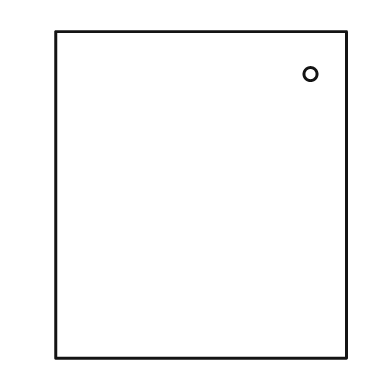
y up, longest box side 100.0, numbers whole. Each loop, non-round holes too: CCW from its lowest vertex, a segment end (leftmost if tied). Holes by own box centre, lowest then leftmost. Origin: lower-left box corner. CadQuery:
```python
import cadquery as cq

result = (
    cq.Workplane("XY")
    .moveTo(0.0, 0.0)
    .lineTo(89.0, 0.0)
    .lineTo(89.0, 100.0)
    .lineTo(0.0, 100.0)
    .close()
    .moveTo(78.0, 87.0)
    .circle(2.0)
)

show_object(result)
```